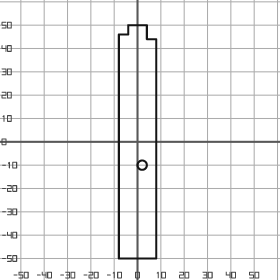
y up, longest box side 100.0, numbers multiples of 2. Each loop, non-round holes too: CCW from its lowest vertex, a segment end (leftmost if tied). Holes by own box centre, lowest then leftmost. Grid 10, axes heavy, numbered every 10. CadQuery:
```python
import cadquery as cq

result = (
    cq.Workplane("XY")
    .moveTo(-8.0, -50.0)
    .lineTo(8.0, -50.0)
    .lineTo(8.0, 44.0)
    .lineTo(4.0, 44.0)
    .lineTo(4.0, 50.0)
    .lineTo(-4.0, 50.0)
    .lineTo(-4.0, 46.0)
    .lineTo(-8.0, 46.0)
    .close()
    .moveTo(2.0, -10.0)
    .circle(2.0)
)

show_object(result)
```